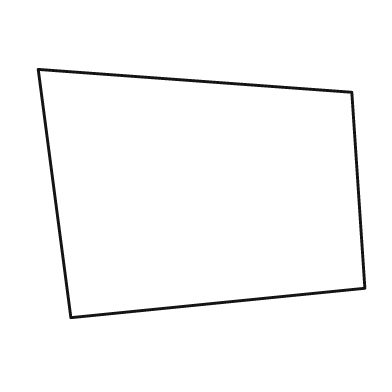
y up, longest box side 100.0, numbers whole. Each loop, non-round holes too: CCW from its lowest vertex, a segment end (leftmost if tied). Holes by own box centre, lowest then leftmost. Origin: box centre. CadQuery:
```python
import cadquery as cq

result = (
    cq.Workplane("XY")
    .moveTo(-40.0, -38.0)
    .lineTo(50.0, -29.0)
    .lineTo(46.0, 31.0)
    .lineTo(-50.0, 38.0)
    .close()
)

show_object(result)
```